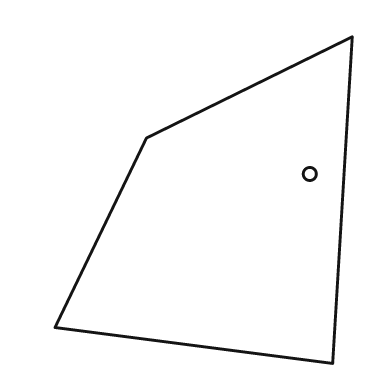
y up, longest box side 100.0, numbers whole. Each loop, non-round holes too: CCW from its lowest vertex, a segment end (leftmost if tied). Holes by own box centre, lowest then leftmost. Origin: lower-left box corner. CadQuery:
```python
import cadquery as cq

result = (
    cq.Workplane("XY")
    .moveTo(85.0, 0.0)
    .lineTo(91.0, 100.0)
    .lineTo(28.0, 69.0)
    .lineTo(0.0, 11.0)
    .close()
    .moveTo(78.0, 58.0)
    .circle(2.0)
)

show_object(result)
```